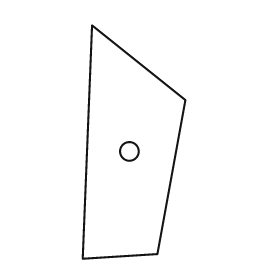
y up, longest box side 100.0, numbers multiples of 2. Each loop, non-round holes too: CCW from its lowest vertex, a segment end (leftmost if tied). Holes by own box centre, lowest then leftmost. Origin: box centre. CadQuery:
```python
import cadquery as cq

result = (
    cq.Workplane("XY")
    .moveTo(-22.0, -50.0)
    .lineTo(10.0, -48.0)
    .lineTo(22.0, 18.0)
    .lineTo(-18.0, 50.0)
    .close()
    .moveTo(-2.0, -4.0)
    .circle(4.0)
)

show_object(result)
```